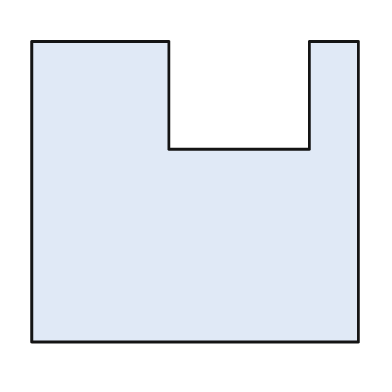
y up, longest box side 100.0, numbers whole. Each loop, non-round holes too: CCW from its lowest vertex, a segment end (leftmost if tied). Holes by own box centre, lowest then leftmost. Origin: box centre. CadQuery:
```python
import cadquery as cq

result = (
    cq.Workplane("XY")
    .moveTo(-50.0, -46.0)
    .lineTo(50.0, -46.0)
    .lineTo(50.0, 46.0)
    .lineTo(35.0, 46.0)
    .lineTo(35.0, 13.0)
    .lineTo(-8.0, 13.0)
    .lineTo(-8.0, 46.0)
    .lineTo(-50.0, 46.0)
    .close()
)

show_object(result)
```